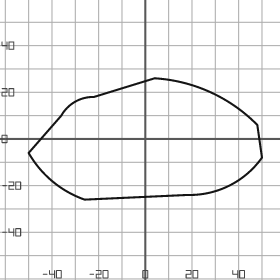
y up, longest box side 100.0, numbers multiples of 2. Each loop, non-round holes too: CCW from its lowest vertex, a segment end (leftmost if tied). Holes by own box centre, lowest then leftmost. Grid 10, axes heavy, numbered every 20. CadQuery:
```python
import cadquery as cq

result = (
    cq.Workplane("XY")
    .moveTo(-26.0, -26.0)
    .lineTo(18.0, -24.0)
    .threePointArc((36.0, -20.0), (50.0, -8.0))
    .lineTo(48.0, 6.0)
    .threePointArc((28.0, 20.0), (4.0, 26.0))
    .lineTo(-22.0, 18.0)
    .threePointArc((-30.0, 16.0), (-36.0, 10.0))
    .lineTo(-50.0, -6.0)
    .threePointArc((-40.0, -18.0), (-26.0, -26.0))
    .close()
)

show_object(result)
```